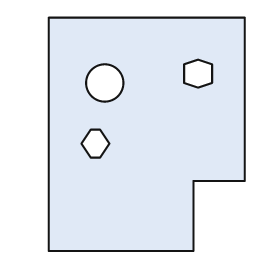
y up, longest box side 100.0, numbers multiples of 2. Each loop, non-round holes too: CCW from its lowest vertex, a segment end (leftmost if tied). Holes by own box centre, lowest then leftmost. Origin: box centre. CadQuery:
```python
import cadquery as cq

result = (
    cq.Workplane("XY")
    .moveTo(-42.0, -50.0)
    .lineTo(20.0, -50.0)
    .lineTo(20.0, -20.0)
    .lineTo(42.0, -20.0)
    .lineTo(42.0, 50.0)
    .lineTo(-42.0, 50.0)
    .close()
    .moveTo(-24.0, -10.0)
    .lineTo(-20.0, -10.0)
    .lineTo(-16.0, -4.0)
    .lineTo(-20.0, 2.0)
    .lineTo(-24.0, 2.0)
    .lineTo(-28.0, -4.0)
    .close()
    .moveTo(-18.0, 22.0)
    .circle(8.0)
    .moveTo(22.0, 20.0)
    .lineTo(28.0, 22.0)
    .lineTo(28.0, 30.0)
    .lineTo(22.0, 32.0)
    .lineTo(16.0, 30.0)
    .lineTo(16.0, 22.0)
    .close()
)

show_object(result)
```